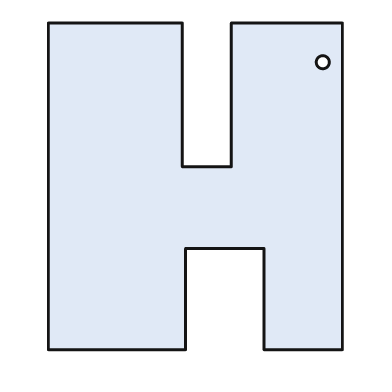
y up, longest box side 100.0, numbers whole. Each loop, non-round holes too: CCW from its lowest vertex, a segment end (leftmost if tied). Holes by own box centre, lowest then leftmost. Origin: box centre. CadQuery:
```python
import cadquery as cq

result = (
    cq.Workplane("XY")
    .moveTo(-45.0, -50.0)
    .lineTo(-3.0, -50.0)
    .lineTo(-3.0, -19.0)
    .lineTo(21.0, -19.0)
    .lineTo(21.0, -50.0)
    .lineTo(45.0, -50.0)
    .lineTo(45.0, 50.0)
    .lineTo(11.0, 50.0)
    .lineTo(11.0, 6.0)
    .lineTo(-4.0, 6.0)
    .lineTo(-4.0, 50.0)
    .lineTo(-45.0, 50.0)
    .close()
    .moveTo(39.0, 38.0)
    .circle(2.0)
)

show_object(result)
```